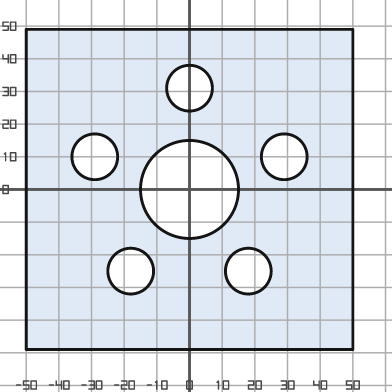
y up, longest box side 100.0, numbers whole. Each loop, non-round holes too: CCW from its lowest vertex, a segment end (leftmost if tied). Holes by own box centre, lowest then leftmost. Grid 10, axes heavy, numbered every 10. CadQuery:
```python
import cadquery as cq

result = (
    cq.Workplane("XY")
    .moveTo(-50.0, -49.0)
    .lineTo(50.0, -49.0)
    .lineTo(50.0, 49.0)
    .lineTo(-50.0, 49.0)
    .close()
    .moveTo(-18.0, -25.0)
    .circle(7.0)
    .moveTo(18.0, -25.0)
    .circle(7.0)
    .moveTo(0.0, 0.0)
    .circle(15.0)
    .moveTo(-29.0, 10.0)
    .circle(7.0)
    .moveTo(29.0, 10.0)
    .circle(7.0)
    .moveTo(0.0, 31.0)
    .circle(7.0)
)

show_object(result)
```